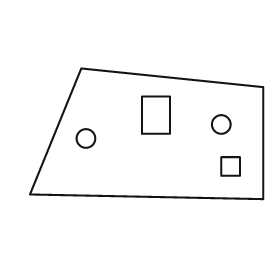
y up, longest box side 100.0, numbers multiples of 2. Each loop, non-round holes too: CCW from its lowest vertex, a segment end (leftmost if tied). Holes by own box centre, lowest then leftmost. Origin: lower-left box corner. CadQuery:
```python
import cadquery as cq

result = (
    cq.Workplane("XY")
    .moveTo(100.0, 0.0)
    .lineTo(100.0, 48.0)
    .lineTo(22.0, 56.0)
    .lineTo(0.0, 2.0)
    .close()
    .moveTo(82.0, 10.0)
    .lineTo(90.0, 10.0)
    .lineTo(90.0, 18.0)
    .lineTo(82.0, 18.0)
    .close()
    .moveTo(24.0, 26.0)
    .circle(4.0)
    .moveTo(82.0, 32.0)
    .circle(4.0)
    .moveTo(48.0, 28.0)
    .lineTo(60.0, 28.0)
    .lineTo(60.0, 44.0)
    .lineTo(48.0, 44.0)
    .close()
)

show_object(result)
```